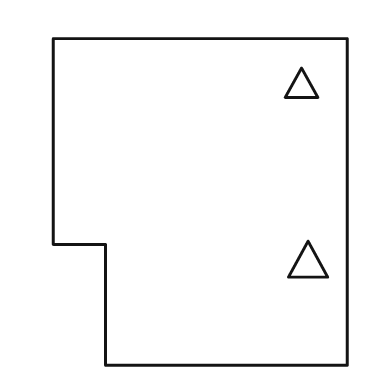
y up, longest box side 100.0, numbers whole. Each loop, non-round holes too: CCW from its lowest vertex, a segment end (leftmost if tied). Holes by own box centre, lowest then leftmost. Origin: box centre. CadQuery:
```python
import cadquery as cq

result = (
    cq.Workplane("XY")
    .moveTo(-29.0, -50.0)
    .lineTo(45.0, -50.0)
    .lineTo(45.0, 50.0)
    .lineTo(-45.0, 50.0)
    .lineTo(-45.0, -13.0)
    .lineTo(-29.0, -13.0)
    .close()
    .moveTo(27.0, -23.0)
    .lineTo(39.0, -23.0)
    .lineTo(33.0, -12.0)
    .close()
    .moveTo(26.0, 32.0)
    .lineTo(36.0, 32.0)
    .lineTo(31.0, 41.0)
    .close()
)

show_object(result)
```